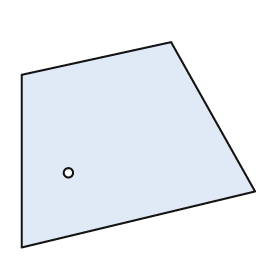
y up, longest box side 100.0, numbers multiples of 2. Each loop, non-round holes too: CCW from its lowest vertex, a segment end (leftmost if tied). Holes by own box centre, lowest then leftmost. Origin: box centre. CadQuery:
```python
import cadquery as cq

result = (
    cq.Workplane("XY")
    .moveTo(-50.0, -44.0)
    .lineTo(50.0, -20.0)
    .lineTo(14.0, 44.0)
    .lineTo(-50.0, 30.0)
    .close()
    .moveTo(-30.0, -12.0)
    .circle(2.0)
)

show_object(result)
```